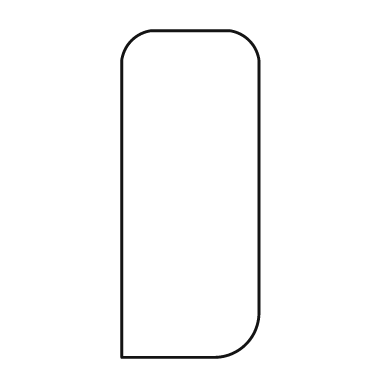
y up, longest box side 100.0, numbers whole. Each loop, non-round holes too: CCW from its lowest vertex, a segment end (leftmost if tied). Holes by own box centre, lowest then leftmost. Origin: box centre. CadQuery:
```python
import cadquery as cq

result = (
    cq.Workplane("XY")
    .moveTo(-21.0, -50.0)
    .lineTo(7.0, -50.0)
    .threePointArc((17.0, -46.0), (21.0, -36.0))
    .lineTo(21.0, 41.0)
    .threePointArc((18.0, 47.0), (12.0, 50.0))
    .lineTo(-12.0, 50.0)
    .threePointArc((-18.0, 47.0), (-21.0, 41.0))
    .close()
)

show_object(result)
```